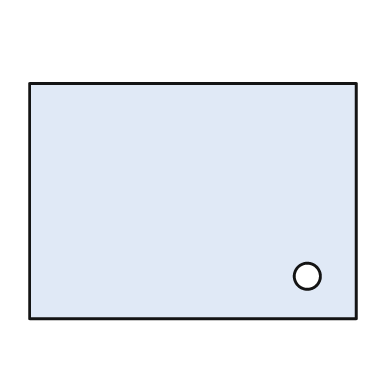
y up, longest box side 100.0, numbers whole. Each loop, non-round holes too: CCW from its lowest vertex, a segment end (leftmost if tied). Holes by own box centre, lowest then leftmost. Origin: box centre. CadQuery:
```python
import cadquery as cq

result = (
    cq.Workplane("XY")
    .moveTo(-50.0, -36.0)
    .lineTo(50.0, -36.0)
    .lineTo(50.0, 36.0)
    .lineTo(-50.0, 36.0)
    .close()
    .moveTo(35.0, -23.0)
    .circle(4.0)
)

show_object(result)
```